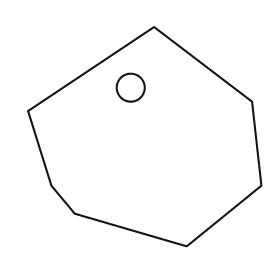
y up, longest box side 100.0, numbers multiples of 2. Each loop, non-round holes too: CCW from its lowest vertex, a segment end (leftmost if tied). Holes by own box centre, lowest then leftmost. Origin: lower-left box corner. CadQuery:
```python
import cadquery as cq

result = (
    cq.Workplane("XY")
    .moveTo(68.0, 0.0)
    .lineTo(100.0, 26.0)
    .lineTo(96.0, 62.0)
    .lineTo(54.0, 94.0)
    .lineTo(0.0, 58.0)
    .lineTo(10.0, 26.0)
    .lineTo(20.0, 14.0)
    .close()
    .moveTo(44.0, 68.0)
    .circle(6.0)
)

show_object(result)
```